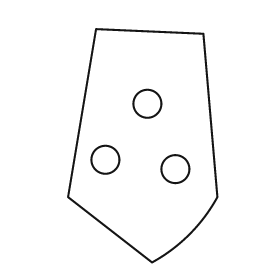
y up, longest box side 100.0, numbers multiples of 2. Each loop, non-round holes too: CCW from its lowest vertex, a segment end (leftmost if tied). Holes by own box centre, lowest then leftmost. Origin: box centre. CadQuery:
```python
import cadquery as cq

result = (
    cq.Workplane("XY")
    .moveTo(4.0, -50.0)
    .threePointArc((20.0, -38.0), (32.0, -22.0))
    .lineTo(26.0, 48.0)
    .lineTo(-20.0, 50.0)
    .lineTo(-32.0, -22.0)
    .close()
    .moveTo(14.0, -10.0)
    .circle(6.0)
    .moveTo(-16.0, -6.0)
    .circle(6.0)
    .moveTo(2.0, 18.0)
    .circle(6.0)
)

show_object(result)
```